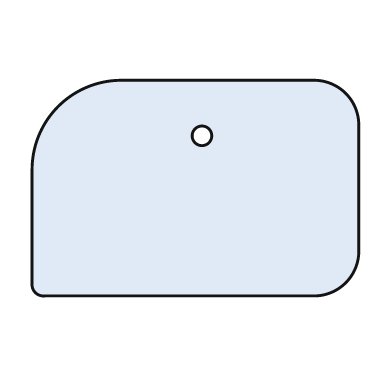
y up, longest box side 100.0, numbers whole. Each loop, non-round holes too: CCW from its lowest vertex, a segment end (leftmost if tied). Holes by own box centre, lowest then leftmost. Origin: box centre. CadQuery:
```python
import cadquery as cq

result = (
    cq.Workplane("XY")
    .moveTo(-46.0, -33.0)
    .lineTo(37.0, -33.0)
    .threePointArc((46.0, -29.0), (50.0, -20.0))
    .lineTo(50.0, 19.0)
    .threePointArc((46.0, 29.0), (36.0, 33.0))
    .lineTo(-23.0, 33.0)
    .threePointArc((-42.0, 25.0), (-50.0, 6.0))
    .lineTo(-50.0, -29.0)
    .threePointArc((-49.0, -32.0), (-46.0, -33.0))
    .close()
    .moveTo(2.0, 16.0)
    .circle(3.0)
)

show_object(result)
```